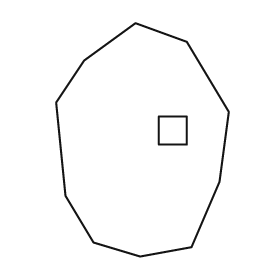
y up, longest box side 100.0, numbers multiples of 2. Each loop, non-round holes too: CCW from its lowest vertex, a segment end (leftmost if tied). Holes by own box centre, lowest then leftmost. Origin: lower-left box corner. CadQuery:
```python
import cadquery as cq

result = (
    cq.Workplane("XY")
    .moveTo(36.0, 0.0)
    .lineTo(58.0, 4.0)
    .lineTo(70.0, 32.0)
    .lineTo(74.0, 62.0)
    .lineTo(56.0, 92.0)
    .lineTo(34.0, 100.0)
    .lineTo(12.0, 84.0)
    .lineTo(0.0, 66.0)
    .lineTo(4.0, 26.0)
    .lineTo(16.0, 6.0)
    .close()
    .moveTo(44.0, 48.0)
    .lineTo(56.0, 48.0)
    .lineTo(56.0, 60.0)
    .lineTo(44.0, 60.0)
    .close()
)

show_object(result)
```